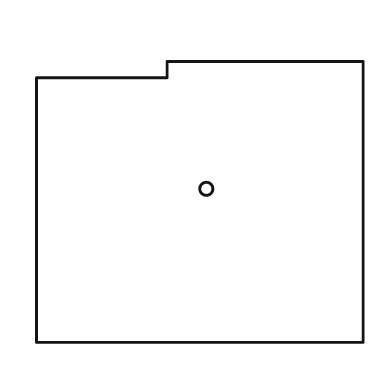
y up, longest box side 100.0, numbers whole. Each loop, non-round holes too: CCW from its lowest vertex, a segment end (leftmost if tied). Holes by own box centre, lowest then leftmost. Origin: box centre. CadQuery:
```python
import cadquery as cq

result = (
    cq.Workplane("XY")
    .moveTo(-50.0, -43.0)
    .lineTo(50.0, -43.0)
    .lineTo(50.0, 43.0)
    .lineTo(-10.0, 43.0)
    .lineTo(-10.0, 38.0)
    .lineTo(-50.0, 38.0)
    .close()
    .moveTo(2.0, 4.0)
    .circle(2.0)
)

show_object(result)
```